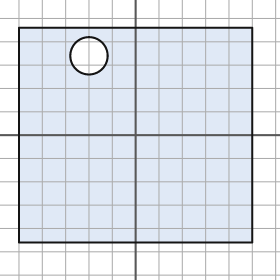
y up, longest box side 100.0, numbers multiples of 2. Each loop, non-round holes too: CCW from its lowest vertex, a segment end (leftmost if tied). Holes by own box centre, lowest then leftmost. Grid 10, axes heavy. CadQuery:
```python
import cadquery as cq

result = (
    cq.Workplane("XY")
    .moveTo(-50.0, -46.0)
    .lineTo(50.0, -46.0)
    .lineTo(50.0, 46.0)
    .lineTo(-50.0, 46.0)
    .close()
    .moveTo(-20.0, 34.0)
    .circle(8.0)
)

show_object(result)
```